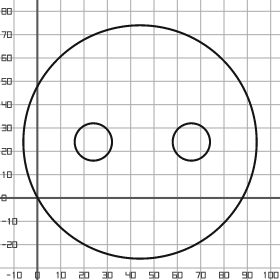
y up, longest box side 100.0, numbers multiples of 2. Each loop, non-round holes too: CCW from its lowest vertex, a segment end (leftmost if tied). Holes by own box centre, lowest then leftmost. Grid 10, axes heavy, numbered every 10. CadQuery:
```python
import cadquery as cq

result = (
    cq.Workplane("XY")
    .moveTo(44.0, 24.0)
    .circle(50.0)
    .moveTo(24.0, 24.0)
    .circle(8.0)
    .moveTo(66.0, 24.0)
    .circle(8.0)
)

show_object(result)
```